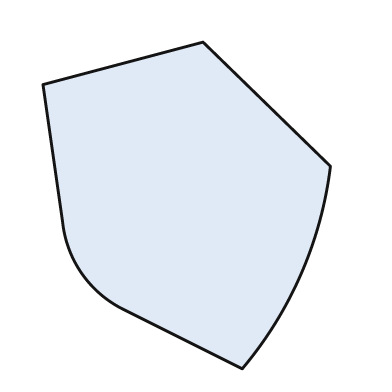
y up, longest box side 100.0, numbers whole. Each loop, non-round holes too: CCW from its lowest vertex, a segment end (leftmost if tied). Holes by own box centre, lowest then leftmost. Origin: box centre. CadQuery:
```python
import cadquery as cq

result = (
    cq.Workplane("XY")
    .moveTo(17.0, -50.0)
    .threePointArc((35.0, -21.0), (44.0, 12.0))
    .lineTo(5.0, 50.0)
    .lineTo(-44.0, 37.0)
    .lineTo(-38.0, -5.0)
    .threePointArc((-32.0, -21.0), (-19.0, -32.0))
    .close()
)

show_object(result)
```